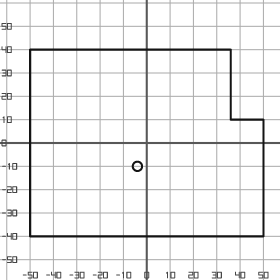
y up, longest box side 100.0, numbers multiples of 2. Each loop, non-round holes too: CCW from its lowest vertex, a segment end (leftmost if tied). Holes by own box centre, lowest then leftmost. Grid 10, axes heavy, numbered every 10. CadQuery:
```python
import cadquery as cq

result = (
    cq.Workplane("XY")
    .moveTo(-50.0, -40.0)
    .lineTo(50.0, -40.0)
    .lineTo(50.0, 10.0)
    .lineTo(36.0, 10.0)
    .lineTo(36.0, 40.0)
    .lineTo(-50.0, 40.0)
    .close()
    .moveTo(-4.0, -10.0)
    .circle(2.0)
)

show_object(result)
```